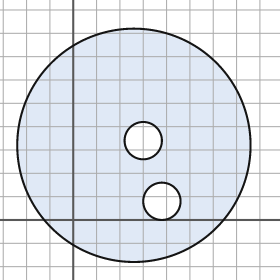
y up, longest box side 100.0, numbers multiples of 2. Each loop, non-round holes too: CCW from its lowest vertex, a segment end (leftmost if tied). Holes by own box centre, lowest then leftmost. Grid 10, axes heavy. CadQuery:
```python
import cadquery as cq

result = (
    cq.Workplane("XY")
    .moveTo(26.0, 32.0)
    .circle(50.0)
    .moveTo(38.0, 8.0)
    .circle(8.0)
    .moveTo(30.0, 34.0)
    .circle(8.0)
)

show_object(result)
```